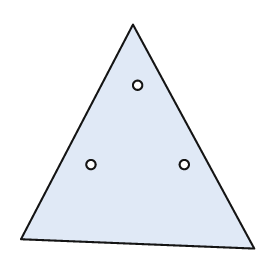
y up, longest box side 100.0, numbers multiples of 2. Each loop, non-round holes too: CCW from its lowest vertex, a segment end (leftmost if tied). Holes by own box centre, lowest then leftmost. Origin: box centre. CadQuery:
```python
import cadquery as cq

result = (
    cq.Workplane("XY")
    .moveTo(50.0, -48.0)
    .lineTo(-2.0, 48.0)
    .lineTo(-50.0, -44.0)
    .close()
    .moveTo(-20.0, -12.0)
    .circle(2.0)
    .moveTo(20.0, -12.0)
    .circle(2.0)
    .moveTo(0.0, 22.0)
    .circle(2.0)
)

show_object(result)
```